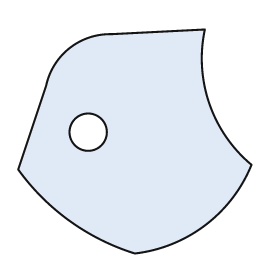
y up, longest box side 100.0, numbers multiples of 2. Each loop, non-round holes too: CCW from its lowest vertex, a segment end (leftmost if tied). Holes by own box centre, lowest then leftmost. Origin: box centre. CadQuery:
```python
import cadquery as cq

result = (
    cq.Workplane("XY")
    .moveTo(0.0, -48.0)
    .threePointArc((30.0, -36.0), (50.0, -10.0))
    .threePointArc((32.0, 16.0), (30.0, 48.0))
    .lineTo(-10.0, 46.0)
    .threePointArc((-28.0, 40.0), (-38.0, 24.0))
    .lineTo(-50.0, -12.0)
    .threePointArc((-28.0, -34.0), (0.0, -48.0))
    .close()
    .moveTo(-20.0, 4.0)
    .circle(8.0)
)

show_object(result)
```